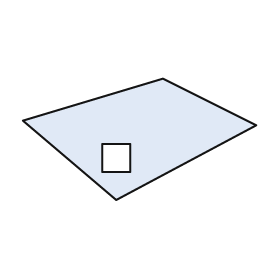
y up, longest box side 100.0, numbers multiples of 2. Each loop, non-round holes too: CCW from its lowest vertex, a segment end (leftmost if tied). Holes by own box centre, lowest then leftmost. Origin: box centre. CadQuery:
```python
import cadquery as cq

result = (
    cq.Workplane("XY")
    .moveTo(-10.0, -26.0)
    .lineTo(50.0, 6.0)
    .lineTo(10.0, 26.0)
    .lineTo(-50.0, 8.0)
    .close()
    .moveTo(-16.0, -14.0)
    .lineTo(-4.0, -14.0)
    .lineTo(-4.0, -2.0)
    .lineTo(-16.0, -2.0)
    .close()
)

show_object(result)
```